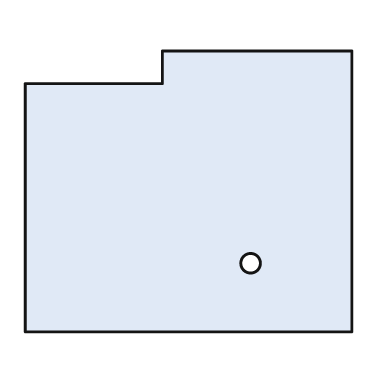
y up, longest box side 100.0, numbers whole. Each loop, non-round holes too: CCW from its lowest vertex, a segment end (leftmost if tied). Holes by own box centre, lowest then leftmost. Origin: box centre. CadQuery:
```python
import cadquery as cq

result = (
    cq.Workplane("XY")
    .moveTo(-50.0, -43.0)
    .lineTo(50.0, -43.0)
    .lineTo(50.0, 43.0)
    .lineTo(-8.0, 43.0)
    .lineTo(-8.0, 33.0)
    .lineTo(-50.0, 33.0)
    .close()
    .moveTo(19.0, -22.0)
    .circle(3.0)
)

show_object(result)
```